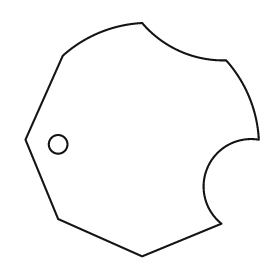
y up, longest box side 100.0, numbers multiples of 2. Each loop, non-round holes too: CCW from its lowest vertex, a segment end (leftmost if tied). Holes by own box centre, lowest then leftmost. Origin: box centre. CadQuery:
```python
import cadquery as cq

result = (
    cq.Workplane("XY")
    .moveTo(0.0, -50.0)
    .lineTo(34.0, -36.0)
    .threePointArc((28.0, -12.0), (50.0, 0.0))
    .threePointArc((46.0, 18.0), (36.0, 34.0))
    .threePointArc((16.0, 38.0), (0.0, 50.0))
    .threePointArc((-18.0, 46.0), (-34.0, 36.0))
    .lineTo(-50.0, 0.0)
    .lineTo(-36.0, -34.0)
    .close()
    .moveTo(-36.0, -2.0)
    .circle(4.0)
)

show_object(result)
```